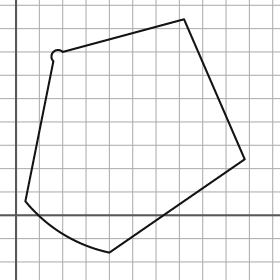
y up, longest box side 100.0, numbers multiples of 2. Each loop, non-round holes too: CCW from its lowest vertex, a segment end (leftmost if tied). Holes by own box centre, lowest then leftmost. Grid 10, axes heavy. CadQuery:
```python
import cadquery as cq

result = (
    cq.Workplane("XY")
    .moveTo(40.0, -16.0)
    .lineTo(98.0, 24.0)
    .lineTo(72.0, 84.0)
    .lineTo(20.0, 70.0)
    .threePointArc((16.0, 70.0), (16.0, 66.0))
    .lineTo(4.0, 6.0)
    .threePointArc((20.0, -8.0), (40.0, -16.0))
    .close()
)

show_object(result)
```